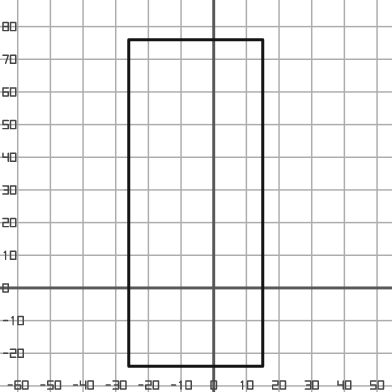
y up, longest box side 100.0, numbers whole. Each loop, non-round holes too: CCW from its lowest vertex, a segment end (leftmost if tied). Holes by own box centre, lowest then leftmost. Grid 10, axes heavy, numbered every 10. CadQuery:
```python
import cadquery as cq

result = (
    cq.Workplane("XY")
    .moveTo(-26.0, -24.0)
    .lineTo(15.0, -24.0)
    .lineTo(15.0, 76.0)
    .lineTo(-26.0, 76.0)
    .close()
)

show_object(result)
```